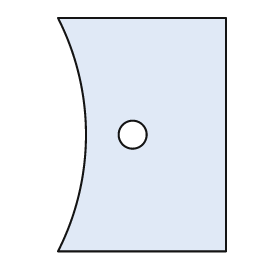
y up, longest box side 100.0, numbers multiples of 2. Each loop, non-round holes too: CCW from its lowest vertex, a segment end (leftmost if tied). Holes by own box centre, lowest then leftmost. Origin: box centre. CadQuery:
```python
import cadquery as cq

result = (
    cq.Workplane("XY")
    .moveTo(-36.0, -50.0)
    .lineTo(36.0, -50.0)
    .lineTo(36.0, 50.0)
    .lineTo(-36.0, 50.0)
    .threePointArc((-24.0, 0.0), (-36.0, -50.0))
    .close()
    .moveTo(-4.0, 0.0)
    .circle(6.0)
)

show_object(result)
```